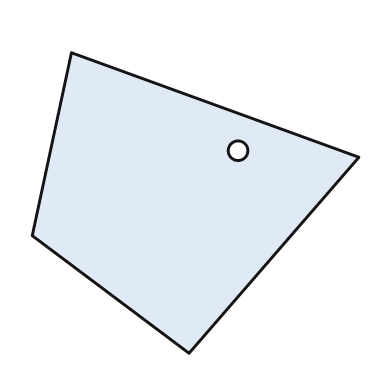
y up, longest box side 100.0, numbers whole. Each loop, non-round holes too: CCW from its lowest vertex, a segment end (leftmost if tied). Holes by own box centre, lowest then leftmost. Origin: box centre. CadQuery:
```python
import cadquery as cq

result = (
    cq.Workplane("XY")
    .moveTo(-2.0, -46.0)
    .lineTo(50.0, 14.0)
    .lineTo(-38.0, 46.0)
    .lineTo(-50.0, -10.0)
    .close()
    .moveTo(13.0, 16.0)
    .circle(3.0)
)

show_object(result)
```